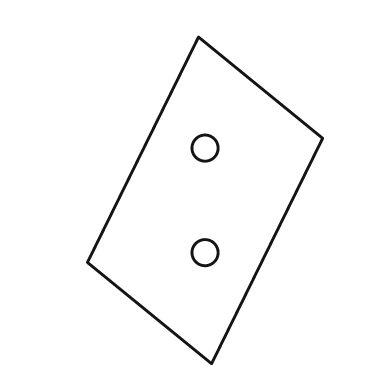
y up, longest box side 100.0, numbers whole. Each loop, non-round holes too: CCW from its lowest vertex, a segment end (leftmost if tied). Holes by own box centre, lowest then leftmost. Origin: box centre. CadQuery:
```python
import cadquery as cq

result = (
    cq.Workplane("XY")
    .moveTo(2.0, -50.0)
    .lineTo(36.0, 19.0)
    .lineTo(-2.0, 50.0)
    .lineTo(-36.0, -19.0)
    .close()
    .moveTo(0.0, -16.0)
    .circle(4.0)
    .moveTo(0.0, 16.0)
    .circle(4.0)
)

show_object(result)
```